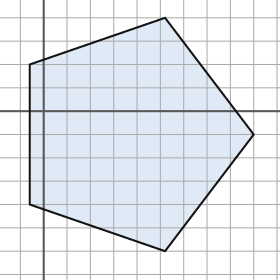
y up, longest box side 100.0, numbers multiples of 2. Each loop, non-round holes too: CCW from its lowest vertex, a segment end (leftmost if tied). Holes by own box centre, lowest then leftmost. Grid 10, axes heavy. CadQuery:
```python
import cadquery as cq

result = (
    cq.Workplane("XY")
    .moveTo(52.0, -60.0)
    .lineTo(90.0, -10.0)
    .lineTo(52.0, 40.0)
    .lineTo(-6.0, 20.0)
    .lineTo(-6.0, -40.0)
    .close()
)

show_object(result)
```